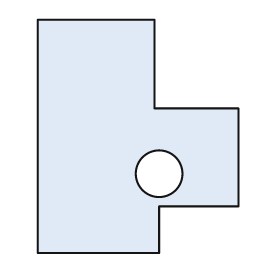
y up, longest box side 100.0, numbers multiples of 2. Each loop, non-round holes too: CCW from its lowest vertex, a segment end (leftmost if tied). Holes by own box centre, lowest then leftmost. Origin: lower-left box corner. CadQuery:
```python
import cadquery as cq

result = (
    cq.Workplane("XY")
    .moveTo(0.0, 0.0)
    .lineTo(52.0, 0.0)
    .lineTo(52.0, 20.0)
    .lineTo(86.0, 20.0)
    .lineTo(86.0, 62.0)
    .lineTo(50.0, 62.0)
    .lineTo(50.0, 100.0)
    .lineTo(0.0, 100.0)
    .close()
    .moveTo(52.0, 34.0)
    .circle(10.0)
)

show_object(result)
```